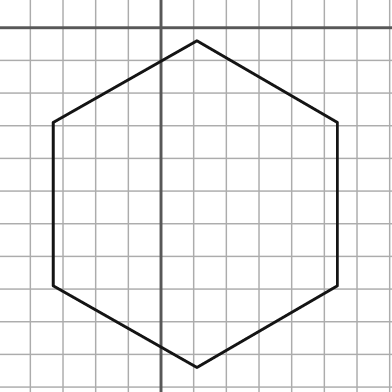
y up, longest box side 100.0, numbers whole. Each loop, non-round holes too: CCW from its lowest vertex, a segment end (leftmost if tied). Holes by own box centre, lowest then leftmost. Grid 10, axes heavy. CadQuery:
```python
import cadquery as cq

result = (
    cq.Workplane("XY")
    .moveTo(11.0, -104.0)
    .lineTo(54.0, -79.0)
    .lineTo(54.0, -29.0)
    .lineTo(11.0, -4.0)
    .lineTo(-33.0, -29.0)
    .lineTo(-33.0, -79.0)
    .close()
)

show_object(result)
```